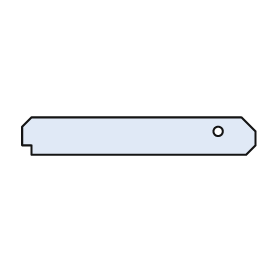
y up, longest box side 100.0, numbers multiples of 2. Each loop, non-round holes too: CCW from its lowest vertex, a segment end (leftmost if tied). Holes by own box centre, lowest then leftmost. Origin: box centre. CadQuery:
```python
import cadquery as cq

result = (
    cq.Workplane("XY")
    .moveTo(-46.0, -8.0)
    .lineTo(46.0, -8.0)
    .lineTo(50.0, -4.0)
    .lineTo(50.0, 2.0)
    .lineTo(44.0, 8.0)
    .lineTo(-46.0, 8.0)
    .lineTo(-50.0, 4.0)
    .lineTo(-50.0, -4.0)
    .lineTo(-46.0, -4.0)
    .close()
    .moveTo(34.0, 2.0)
    .circle(2.0)
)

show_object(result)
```